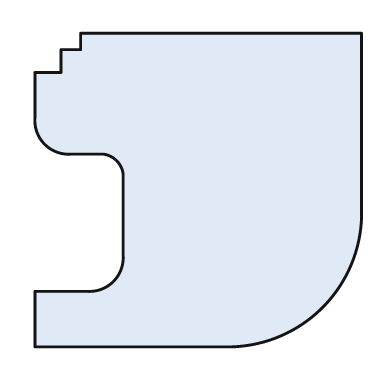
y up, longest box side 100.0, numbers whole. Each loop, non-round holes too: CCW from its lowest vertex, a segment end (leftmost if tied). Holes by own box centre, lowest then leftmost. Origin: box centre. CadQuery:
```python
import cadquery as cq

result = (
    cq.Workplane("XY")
    .moveTo(-50.0, -48.0)
    .lineTo(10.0, -48.0)
    .threePointArc((38.0, -36.0), (50.0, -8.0))
    .lineTo(50.0, 48.0)
    .lineTo(-36.0, 48.0)
    .lineTo(-36.0, 43.0)
    .lineTo(-42.0, 43.0)
    .lineTo(-42.0, 36.0)
    .lineTo(-50.0, 36.0)
    .lineTo(-50.0, 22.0)
    .threePointArc((-47.0, 14.0), (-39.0, 11.0))
    .lineTo(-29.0, 11.0)
    .threePointArc((-25.0, 9.0), (-23.0, 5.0))
    .lineTo(-23.0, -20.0)
    .threePointArc((-26.0, -28.0), (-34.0, -31.0))
    .lineTo(-50.0, -31.0)
    .close()
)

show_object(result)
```